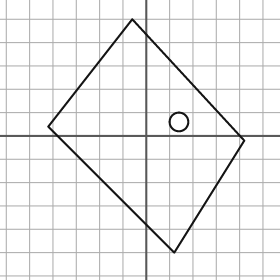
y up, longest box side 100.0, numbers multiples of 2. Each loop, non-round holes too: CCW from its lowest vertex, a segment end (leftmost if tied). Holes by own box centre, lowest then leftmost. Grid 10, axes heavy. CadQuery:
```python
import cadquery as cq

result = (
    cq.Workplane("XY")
    .moveTo(12.0, -50.0)
    .lineTo(42.0, -2.0)
    .lineTo(-6.0, 50.0)
    .lineTo(-42.0, 4.0)
    .close()
    .moveTo(14.0, 6.0)
    .circle(4.0)
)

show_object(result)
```